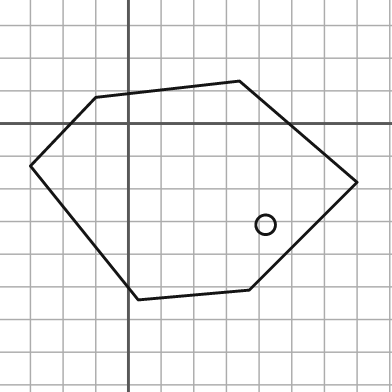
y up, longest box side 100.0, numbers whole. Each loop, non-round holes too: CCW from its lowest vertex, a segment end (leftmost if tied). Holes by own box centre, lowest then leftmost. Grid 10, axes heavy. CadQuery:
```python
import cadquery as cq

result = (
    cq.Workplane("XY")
    .moveTo(3.0, -54.0)
    .lineTo(37.0, -51.0)
    .lineTo(70.0, -18.0)
    .lineTo(34.0, 13.0)
    .lineTo(-10.0, 8.0)
    .lineTo(-30.0, -13.0)
    .close()
    .moveTo(42.0, -31.0)
    .circle(3.0)
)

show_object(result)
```